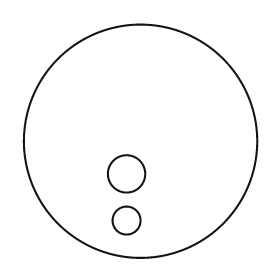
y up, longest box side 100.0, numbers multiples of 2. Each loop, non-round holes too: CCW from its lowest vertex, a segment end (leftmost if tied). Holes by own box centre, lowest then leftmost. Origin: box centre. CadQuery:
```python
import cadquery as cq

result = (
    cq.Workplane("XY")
    .moveTo(0.0, 0.0)
    .circle(50.0)
    .moveTo(-6.0, -34.0)
    .circle(6.0)
    .moveTo(-6.0, -14.0)
    .circle(8.0)
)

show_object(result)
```